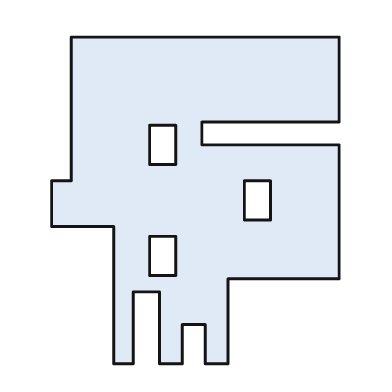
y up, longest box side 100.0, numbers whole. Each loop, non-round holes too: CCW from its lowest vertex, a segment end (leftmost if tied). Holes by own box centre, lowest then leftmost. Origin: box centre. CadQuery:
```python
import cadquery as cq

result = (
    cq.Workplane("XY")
    .moveTo(-25.0, -50.0)
    .lineTo(-19.0, -50.0)
    .lineTo(-19.0, -28.0)
    .lineTo(-11.0, -28.0)
    .lineTo(-11.0, -50.0)
    .lineTo(-4.0, -50.0)
    .lineTo(-4.0, -38.0)
    .lineTo(3.0, -38.0)
    .lineTo(3.0, -50.0)
    .lineTo(10.0, -50.0)
    .lineTo(10.0, -24.0)
    .lineTo(44.0, -24.0)
    .lineTo(44.0, 17.0)
    .lineTo(2.0, 17.0)
    .lineTo(2.0, 24.0)
    .lineTo(44.0, 24.0)
    .lineTo(44.0, 50.0)
    .lineTo(-38.0, 50.0)
    .lineTo(-38.0, 6.0)
    .lineTo(-44.0, 6.0)
    .lineTo(-44.0, -8.0)
    .lineTo(-25.0, -8.0)
    .close()
    .moveTo(-14.0, -23.0)
    .lineTo(-6.0, -23.0)
    .lineTo(-6.0, -11.0)
    .lineTo(-14.0, -11.0)
    .close()
    .moveTo(15.0, -6.0)
    .lineTo(23.0, -6.0)
    .lineTo(23.0, 6.0)
    .lineTo(15.0, 6.0)
    .close()
    .moveTo(-14.0, 11.0)
    .lineTo(-6.0, 11.0)
    .lineTo(-6.0, 23.0)
    .lineTo(-14.0, 23.0)
    .close()
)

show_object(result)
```